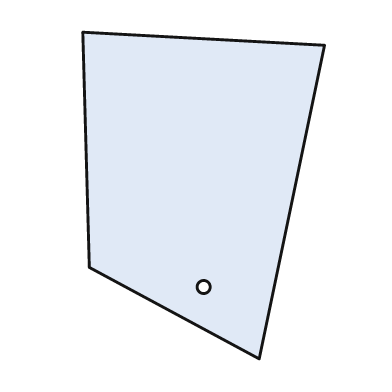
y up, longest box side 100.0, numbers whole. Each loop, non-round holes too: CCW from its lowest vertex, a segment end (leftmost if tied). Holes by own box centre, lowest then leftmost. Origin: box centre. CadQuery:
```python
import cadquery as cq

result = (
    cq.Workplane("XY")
    .moveTo(17.0, -50.0)
    .lineTo(37.0, 46.0)
    .lineTo(-37.0, 50.0)
    .lineTo(-35.0, -22.0)
    .close()
    .moveTo(0.0, -28.0)
    .circle(2.0)
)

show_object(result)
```